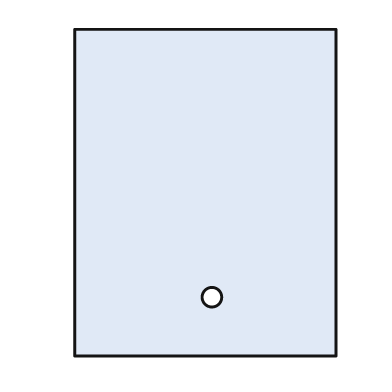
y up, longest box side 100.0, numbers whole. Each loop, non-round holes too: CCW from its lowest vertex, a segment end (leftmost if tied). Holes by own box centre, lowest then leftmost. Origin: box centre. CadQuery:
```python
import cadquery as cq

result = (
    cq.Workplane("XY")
    .moveTo(-40.0, -50.0)
    .lineTo(40.0, -50.0)
    .lineTo(40.0, 50.0)
    .lineTo(-40.0, 50.0)
    .close()
    .moveTo(2.0, -32.0)
    .circle(3.0)
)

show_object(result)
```